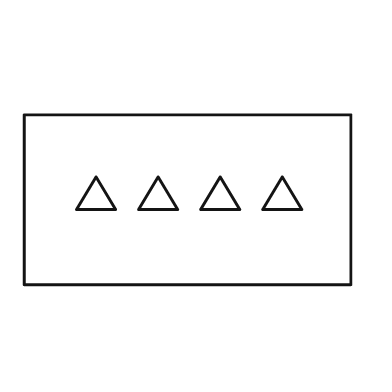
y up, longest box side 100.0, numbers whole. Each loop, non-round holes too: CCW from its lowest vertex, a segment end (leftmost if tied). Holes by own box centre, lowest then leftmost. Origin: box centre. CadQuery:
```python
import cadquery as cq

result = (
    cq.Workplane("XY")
    .moveTo(-50.0, -26.0)
    .lineTo(50.0, -26.0)
    .lineTo(50.0, 26.0)
    .lineTo(-50.0, 26.0)
    .close()
    .moveTo(-34.0, -3.0)
    .lineTo(-22.0, -3.0)
    .lineTo(-28.0, 7.0)
    .close()
    .moveTo(-15.0, -3.0)
    .lineTo(-3.0, -3.0)
    .lineTo(-9.0, 7.0)
    .close()
    .moveTo(4.0, -3.0)
    .lineTo(16.0, -3.0)
    .lineTo(10.0, 7.0)
    .close()
    .moveTo(23.0, -3.0)
    .lineTo(35.0, -3.0)
    .lineTo(29.0, 7.0)
    .close()
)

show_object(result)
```